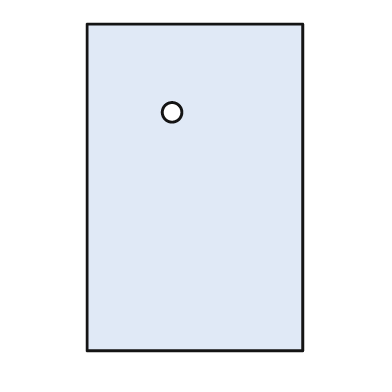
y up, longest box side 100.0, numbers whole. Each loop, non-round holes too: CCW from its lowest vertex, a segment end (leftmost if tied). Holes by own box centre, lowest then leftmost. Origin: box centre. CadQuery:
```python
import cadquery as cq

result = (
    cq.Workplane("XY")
    .moveTo(-33.0, -50.0)
    .lineTo(33.0, -50.0)
    .lineTo(33.0, 50.0)
    .lineTo(-33.0, 50.0)
    .close()
    .moveTo(-7.0, 23.0)
    .circle(3.0)
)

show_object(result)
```